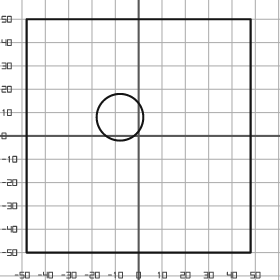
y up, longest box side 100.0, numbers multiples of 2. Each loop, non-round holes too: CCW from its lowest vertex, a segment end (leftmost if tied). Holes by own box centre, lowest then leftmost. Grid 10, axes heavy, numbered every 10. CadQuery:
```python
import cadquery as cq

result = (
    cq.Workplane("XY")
    .moveTo(-48.0, -50.0)
    .lineTo(48.0, -50.0)
    .lineTo(48.0, 50.0)
    .lineTo(-48.0, 50.0)
    .close()
    .moveTo(-8.0, 8.0)
    .circle(10.0)
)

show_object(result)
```